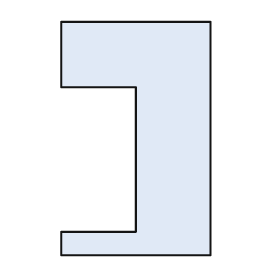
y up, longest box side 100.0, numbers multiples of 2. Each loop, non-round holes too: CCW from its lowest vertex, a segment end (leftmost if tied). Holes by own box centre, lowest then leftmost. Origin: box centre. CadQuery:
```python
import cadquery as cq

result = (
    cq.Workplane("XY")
    .moveTo(-32.0, -50.0)
    .lineTo(32.0, -50.0)
    .lineTo(32.0, 50.0)
    .lineTo(-32.0, 50.0)
    .lineTo(-32.0, 22.0)
    .lineTo(0.0, 22.0)
    .lineTo(0.0, -40.0)
    .lineTo(-32.0, -40.0)
    .close()
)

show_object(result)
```